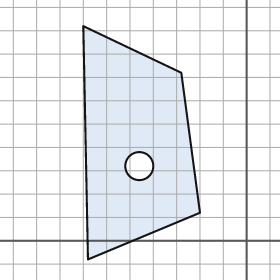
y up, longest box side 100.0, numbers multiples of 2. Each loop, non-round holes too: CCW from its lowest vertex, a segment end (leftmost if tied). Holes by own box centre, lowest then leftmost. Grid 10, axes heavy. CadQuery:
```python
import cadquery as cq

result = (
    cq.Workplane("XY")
    .moveTo(-68.0, -8.0)
    .lineTo(-20.0, 12.0)
    .lineTo(-28.0, 72.0)
    .lineTo(-70.0, 92.0)
    .close()
    .moveTo(-46.0, 32.0)
    .circle(6.0)
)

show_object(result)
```